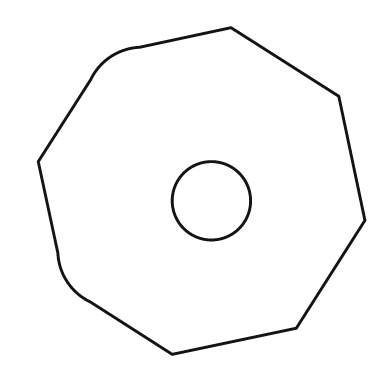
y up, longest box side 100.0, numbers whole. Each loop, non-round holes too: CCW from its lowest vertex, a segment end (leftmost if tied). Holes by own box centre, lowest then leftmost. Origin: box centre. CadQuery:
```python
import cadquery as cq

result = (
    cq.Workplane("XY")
    .moveTo(-9.0, -50.0)
    .lineTo(29.0, -42.0)
    .lineTo(50.0, -9.0)
    .lineTo(42.0, 29.0)
    .lineTo(9.0, 50.0)
    .lineTo(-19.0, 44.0)
    .threePointArc((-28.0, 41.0), (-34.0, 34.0))
    .lineTo(-50.0, 9.0)
    .lineTo(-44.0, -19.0)
    .threePointArc((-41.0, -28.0), (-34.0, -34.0))
    .close()
    .moveTo(3.0, -3.0)
    .circle(12.0)
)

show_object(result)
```